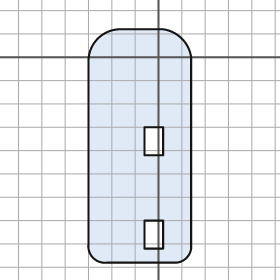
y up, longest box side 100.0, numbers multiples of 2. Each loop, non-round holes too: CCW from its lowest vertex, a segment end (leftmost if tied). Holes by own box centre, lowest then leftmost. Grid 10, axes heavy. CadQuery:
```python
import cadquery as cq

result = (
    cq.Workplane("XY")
    .moveTo(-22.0, -88.0)
    .lineTo(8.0, -88.0)
    .threePointArc((12.0, -86.0), (14.0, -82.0))
    .lineTo(14.0, 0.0)
    .threePointArc((10.0, 8.0), (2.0, 12.0))
    .lineTo(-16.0, 12.0)
    .threePointArc((-26.0, 8.0), (-30.0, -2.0))
    .lineTo(-30.0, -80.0)
    .threePointArc((-28.0, -86.0), (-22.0, -88.0))
    .close()
    .moveTo(-6.0, -82.0)
    .lineTo(2.0, -82.0)
    .lineTo(2.0, -70.0)
    .lineTo(-6.0, -70.0)
    .close()
    .moveTo(-6.0, -42.0)
    .lineTo(2.0, -42.0)
    .lineTo(2.0, -30.0)
    .lineTo(-6.0, -30.0)
    .close()
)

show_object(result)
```